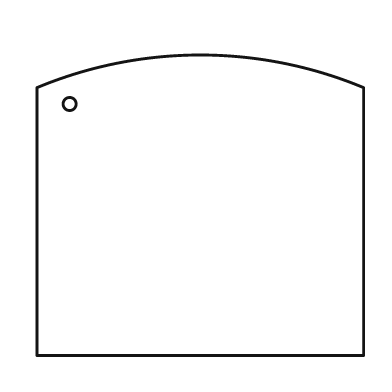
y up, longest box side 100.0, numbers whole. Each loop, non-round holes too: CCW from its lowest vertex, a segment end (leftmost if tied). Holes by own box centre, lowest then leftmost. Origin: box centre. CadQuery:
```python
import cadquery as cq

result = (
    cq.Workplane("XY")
    .moveTo(-50.0, -46.0)
    .lineTo(50.0, -46.0)
    .lineTo(50.0, 36.0)
    .threePointArc((0.0, 46.0), (-50.0, 36.0))
    .close()
    .moveTo(-40.0, 31.0)
    .circle(2.0)
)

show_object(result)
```